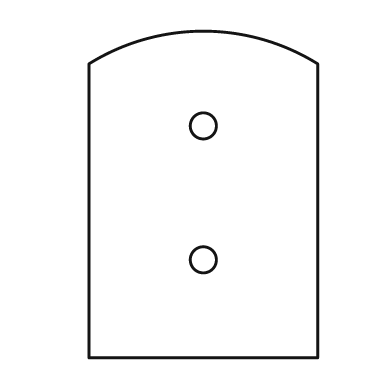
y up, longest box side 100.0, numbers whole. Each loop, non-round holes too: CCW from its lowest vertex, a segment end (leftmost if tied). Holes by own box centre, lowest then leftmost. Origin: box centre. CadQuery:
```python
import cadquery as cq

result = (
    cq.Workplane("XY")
    .moveTo(-35.0, -50.0)
    .lineTo(35.0, -50.0)
    .lineTo(35.0, 40.0)
    .threePointArc((0.0, 50.0), (-35.0, 40.0))
    .close()
    .moveTo(0.0, -20.0)
    .circle(4.0)
    .moveTo(0.0, 21.0)
    .circle(4.0)
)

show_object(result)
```